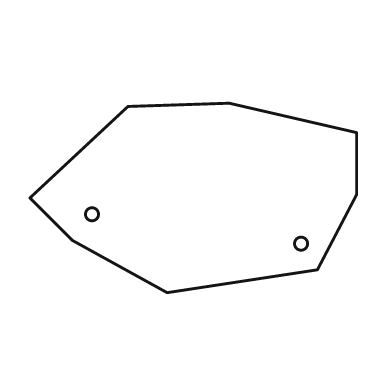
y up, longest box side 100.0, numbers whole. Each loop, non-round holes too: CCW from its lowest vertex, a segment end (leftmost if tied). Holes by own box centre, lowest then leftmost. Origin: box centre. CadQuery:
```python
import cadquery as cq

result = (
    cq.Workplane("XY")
    .moveTo(-8.0, -29.0)
    .lineTo(38.0, -22.0)
    .lineTo(50.0, 1.0)
    .lineTo(50.0, 20.0)
    .lineTo(11.0, 29.0)
    .lineTo(-20.0, 28.0)
    .lineTo(-50.0, 0.0)
    .lineTo(-37.0, -13.0)
    .close()
    .moveTo(33.0, -14.0)
    .circle(2.0)
    .moveTo(-31.0, -5.0)
    .circle(2.0)
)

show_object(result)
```